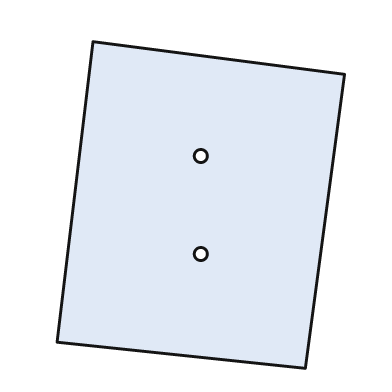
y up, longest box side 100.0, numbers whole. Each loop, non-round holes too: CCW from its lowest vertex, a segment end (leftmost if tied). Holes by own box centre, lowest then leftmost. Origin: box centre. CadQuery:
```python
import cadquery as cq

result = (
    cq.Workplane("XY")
    .moveTo(32.0, -50.0)
    .lineTo(44.0, 40.0)
    .lineTo(-33.0, 50.0)
    .lineTo(-44.0, -42.0)
    .close()
    .moveTo(0.0, -15.0)
    .circle(2.0)
    .moveTo(0.0, 15.0)
    .circle(2.0)
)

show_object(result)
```